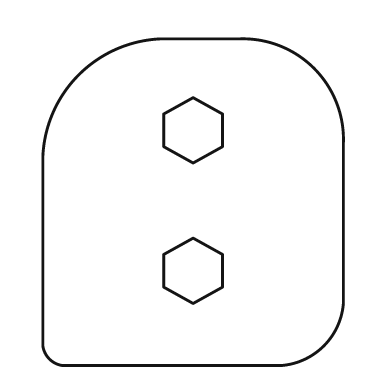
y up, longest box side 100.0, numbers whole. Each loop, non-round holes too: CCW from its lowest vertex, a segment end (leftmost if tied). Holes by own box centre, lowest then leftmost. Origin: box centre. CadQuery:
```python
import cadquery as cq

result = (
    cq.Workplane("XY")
    .moveTo(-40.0, -50.0)
    .lineTo(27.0, -50.0)
    .threePointArc((40.0, -44.0), (46.0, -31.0))
    .lineTo(46.0, 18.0)
    .threePointArc((37.0, 41.0), (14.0, 50.0))
    .lineTo(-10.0, 50.0)
    .threePointArc((-35.0, 39.0), (-46.0, 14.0))
    .lineTo(-46.0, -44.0)
    .threePointArc((-44.0, -48.0), (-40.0, -50.0))
    .close()
    .moveTo(0.0, -31.0)
    .lineTo(9.0, -26.0)
    .lineTo(9.0, -16.0)
    .lineTo(0.0, -11.0)
    .lineTo(-9.0, -16.0)
    .lineTo(-9.0, -26.0)
    .close()
    .moveTo(0.0, 12.0)
    .lineTo(9.0, 17.0)
    .lineTo(9.0, 27.0)
    .lineTo(0.0, 32.0)
    .lineTo(-9.0, 27.0)
    .lineTo(-9.0, 17.0)
    .close()
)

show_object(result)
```